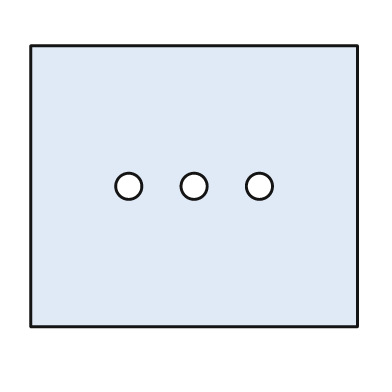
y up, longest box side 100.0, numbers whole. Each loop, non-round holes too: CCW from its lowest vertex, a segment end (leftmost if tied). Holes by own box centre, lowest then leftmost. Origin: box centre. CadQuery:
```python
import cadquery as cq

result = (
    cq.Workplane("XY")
    .moveTo(-50.0, -43.0)
    .lineTo(50.0, -43.0)
    .lineTo(50.0, 43.0)
    .lineTo(-50.0, 43.0)
    .close()
    .moveTo(-20.0, 0.0)
    .circle(4.0)
    .moveTo(0.0, 0.0)
    .circle(4.0)
    .moveTo(20.0, 0.0)
    .circle(4.0)
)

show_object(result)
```